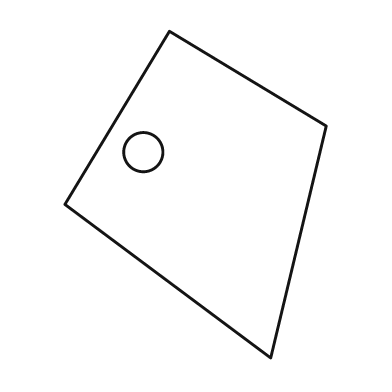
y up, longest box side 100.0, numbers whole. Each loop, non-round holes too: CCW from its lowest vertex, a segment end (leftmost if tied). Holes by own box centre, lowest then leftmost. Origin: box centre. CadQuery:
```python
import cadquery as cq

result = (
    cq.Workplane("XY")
    .moveTo(23.0, -50.0)
    .lineTo(40.0, 21.0)
    .lineTo(-8.0, 50.0)
    .lineTo(-40.0, -3.0)
    .close()
    .moveTo(-16.0, 13.0)
    .circle(6.0)
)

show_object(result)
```